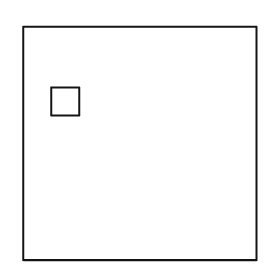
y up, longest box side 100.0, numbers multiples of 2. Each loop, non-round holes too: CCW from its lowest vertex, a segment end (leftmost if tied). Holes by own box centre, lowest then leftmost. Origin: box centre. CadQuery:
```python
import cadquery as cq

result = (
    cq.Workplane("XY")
    .moveTo(-50.0, -50.0)
    .lineTo(50.0, -50.0)
    .lineTo(50.0, 50.0)
    .lineTo(-50.0, 50.0)
    .close()
    .moveTo(-38.0, 12.0)
    .lineTo(-26.0, 12.0)
    .lineTo(-26.0, 24.0)
    .lineTo(-38.0, 24.0)
    .close()
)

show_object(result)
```